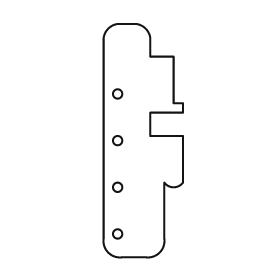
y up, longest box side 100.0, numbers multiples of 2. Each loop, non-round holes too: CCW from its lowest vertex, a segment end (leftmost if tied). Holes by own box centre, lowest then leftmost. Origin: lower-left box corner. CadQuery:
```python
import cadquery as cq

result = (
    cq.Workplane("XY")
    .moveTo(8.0, 0.0)
    .lineTo(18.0, 0.0)
    .threePointArc((24.0, 2.0), (26.0, 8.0))
    .lineTo(26.0, 32.0)
    .threePointArc((30.0, 30.0), (34.0, 32.0))
    .lineTo(34.0, 52.0)
    .lineTo(20.0, 52.0)
    .lineTo(20.0, 62.0)
    .lineTo(34.0, 62.0)
    .lineTo(34.0, 66.0)
    .lineTo(30.0, 66.0)
    .lineTo(30.0, 86.0)
    .lineTo(20.0, 86.0)
    .lineTo(20.0, 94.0)
    .threePointArc((18.0, 98.0), (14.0, 100.0))
    .lineTo(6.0, 100.0)
    .threePointArc((2.0, 98.0), (0.0, 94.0))
    .lineTo(0.0, 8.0)
    .threePointArc((2.0, 2.0), (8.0, 0.0))
    .close()
    .moveTo(6.0, 10.0)
    .circle(2.0)
    .moveTo(6.0, 30.0)
    .circle(2.0)
    .moveTo(6.0, 50.0)
    .circle(2.0)
    .moveTo(6.0, 70.0)
    .circle(2.0)
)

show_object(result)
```